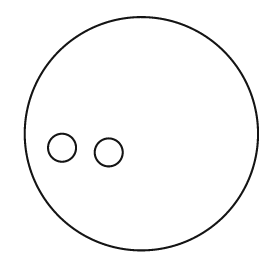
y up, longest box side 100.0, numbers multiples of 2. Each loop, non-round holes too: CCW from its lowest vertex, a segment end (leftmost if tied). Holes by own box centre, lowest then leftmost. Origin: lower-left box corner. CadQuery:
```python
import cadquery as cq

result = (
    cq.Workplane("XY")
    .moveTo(50.0, 50.0)
    .circle(50.0)
    .moveTo(36.0, 42.0)
    .circle(6.0)
    .moveTo(16.0, 44.0)
    .circle(6.0)
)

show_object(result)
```